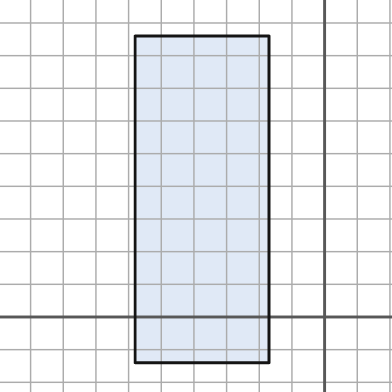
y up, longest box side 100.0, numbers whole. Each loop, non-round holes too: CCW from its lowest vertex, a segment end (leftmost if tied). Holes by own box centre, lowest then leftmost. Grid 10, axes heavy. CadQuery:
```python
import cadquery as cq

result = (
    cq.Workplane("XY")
    .moveTo(-58.0, -14.0)
    .lineTo(-17.0, -14.0)
    .lineTo(-17.0, 86.0)
    .lineTo(-58.0, 86.0)
    .close()
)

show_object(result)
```